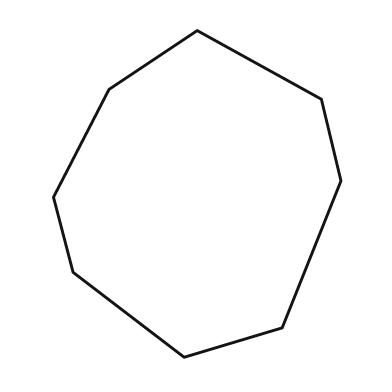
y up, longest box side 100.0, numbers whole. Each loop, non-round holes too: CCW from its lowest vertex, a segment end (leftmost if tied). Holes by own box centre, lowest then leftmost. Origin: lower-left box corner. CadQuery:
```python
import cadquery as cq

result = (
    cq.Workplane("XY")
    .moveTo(40.0, 0.0)
    .lineTo(70.0, 9.0)
    .lineTo(88.0, 54.0)
    .lineTo(82.0, 79.0)
    .lineTo(44.0, 100.0)
    .lineTo(17.0, 82.0)
    .lineTo(0.0, 49.0)
    .lineTo(6.0, 26.0)
    .close()
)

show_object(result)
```